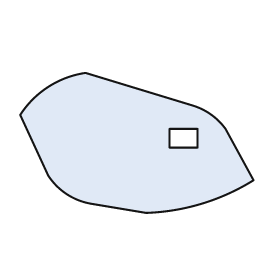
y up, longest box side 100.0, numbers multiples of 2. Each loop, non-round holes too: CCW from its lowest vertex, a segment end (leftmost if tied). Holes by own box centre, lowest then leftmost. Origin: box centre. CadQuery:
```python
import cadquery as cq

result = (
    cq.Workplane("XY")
    .moveTo(4.0, -30.0)
    .threePointArc((28.0, -26.0), (50.0, -16.0))
    .lineTo(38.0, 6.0)
    .threePointArc((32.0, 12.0), (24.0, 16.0))
    .lineTo(-22.0, 30.0)
    .threePointArc((-38.0, 24.0), (-50.0, 12.0))
    .lineTo(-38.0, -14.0)
    .threePointArc((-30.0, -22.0), (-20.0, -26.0))
    .close()
    .moveTo(14.0, -2.0)
    .lineTo(26.0, -2.0)
    .lineTo(26.0, 6.0)
    .lineTo(14.0, 6.0)
    .close()
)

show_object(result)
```